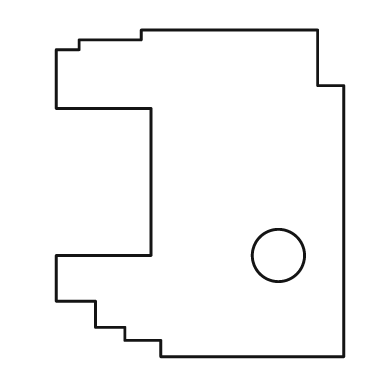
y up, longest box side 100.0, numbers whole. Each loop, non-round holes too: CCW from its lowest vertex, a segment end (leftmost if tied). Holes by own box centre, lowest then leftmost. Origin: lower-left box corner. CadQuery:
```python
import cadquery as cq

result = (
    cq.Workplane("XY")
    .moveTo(32.0, 0.0)
    .lineTo(88.0, 0.0)
    .lineTo(88.0, 83.0)
    .lineTo(80.0, 83.0)
    .lineTo(80.0, 100.0)
    .lineTo(26.0, 100.0)
    .lineTo(26.0, 97.0)
    .lineTo(7.0, 97.0)
    .lineTo(7.0, 94.0)
    .lineTo(0.0, 94.0)
    .lineTo(0.0, 76.0)
    .lineTo(29.0, 76.0)
    .lineTo(29.0, 31.0)
    .lineTo(0.0, 31.0)
    .lineTo(0.0, 17.0)
    .lineTo(12.0, 17.0)
    .lineTo(12.0, 9.0)
    .lineTo(21.0, 9.0)
    .lineTo(21.0, 5.0)
    .lineTo(32.0, 5.0)
    .close()
    .moveTo(68.0, 31.0)
    .circle(8.0)
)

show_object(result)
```